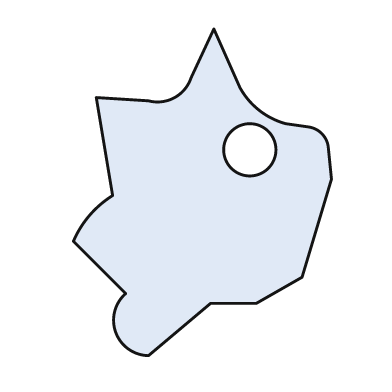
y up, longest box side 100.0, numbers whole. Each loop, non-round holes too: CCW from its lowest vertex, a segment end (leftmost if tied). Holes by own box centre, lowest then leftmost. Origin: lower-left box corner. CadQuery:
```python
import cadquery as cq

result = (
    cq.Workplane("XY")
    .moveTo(23.0, 0.0)
    .lineTo(42.0, 16.0)
    .lineTo(56.0, 16.0)
    .lineTo(70.0, 24.0)
    .lineTo(79.0, 54.0)
    .lineTo(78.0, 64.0)
    .threePointArc((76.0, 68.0), (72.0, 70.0))
    .lineTo(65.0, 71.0)
    .threePointArc((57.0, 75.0), (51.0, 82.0))
    .lineTo(43.0, 100.0)
    .lineTo(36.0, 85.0)
    .threePointArc((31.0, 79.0), (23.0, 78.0))
    .lineTo(7.0, 79.0)
    .lineTo(12.0, 49.0)
    .threePointArc((5.0, 43.0), (0.0, 35.0))
    .lineTo(16.0, 19.0)
    .threePointArc((13.0, 7.0), (23.0, 0.0))
    .close()
    .moveTo(54.0, 63.0)
    .circle(8.0)
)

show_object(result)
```